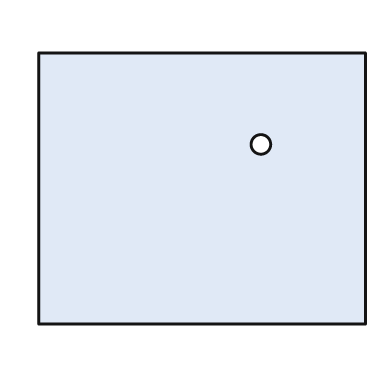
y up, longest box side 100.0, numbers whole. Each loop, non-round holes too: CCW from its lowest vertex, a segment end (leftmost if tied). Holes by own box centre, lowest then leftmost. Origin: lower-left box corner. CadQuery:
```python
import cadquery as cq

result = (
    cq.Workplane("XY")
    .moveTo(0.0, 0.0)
    .lineTo(100.0, 0.0)
    .lineTo(100.0, 83.0)
    .lineTo(0.0, 83.0)
    .close()
    .moveTo(68.0, 55.0)
    .circle(3.0)
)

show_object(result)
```